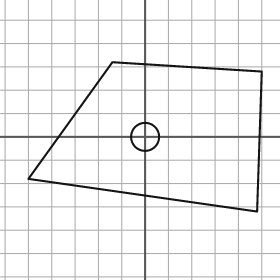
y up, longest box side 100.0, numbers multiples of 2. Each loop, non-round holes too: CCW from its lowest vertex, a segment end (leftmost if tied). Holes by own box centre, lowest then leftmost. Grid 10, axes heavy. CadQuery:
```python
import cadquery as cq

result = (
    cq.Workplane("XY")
    .moveTo(48.0, -32.0)
    .lineTo(50.0, 28.0)
    .lineTo(-14.0, 32.0)
    .lineTo(-50.0, -18.0)
    .close()
    .moveTo(0.0, 0.0)
    .circle(6.0)
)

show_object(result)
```